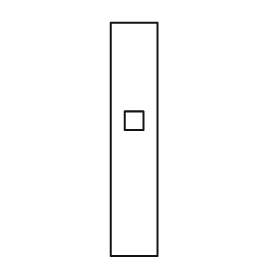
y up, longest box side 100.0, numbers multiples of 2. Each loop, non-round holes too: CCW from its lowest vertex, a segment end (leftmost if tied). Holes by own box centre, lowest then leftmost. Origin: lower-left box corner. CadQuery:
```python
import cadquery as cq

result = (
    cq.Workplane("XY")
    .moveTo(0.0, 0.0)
    .lineTo(20.0, 0.0)
    .lineTo(20.0, 100.0)
    .lineTo(0.0, 100.0)
    .close()
    .moveTo(6.0, 54.0)
    .lineTo(14.0, 54.0)
    .lineTo(14.0, 62.0)
    .lineTo(6.0, 62.0)
    .close()
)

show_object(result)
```